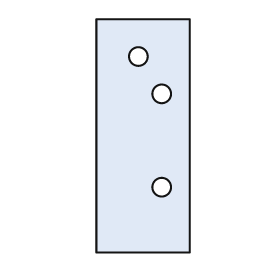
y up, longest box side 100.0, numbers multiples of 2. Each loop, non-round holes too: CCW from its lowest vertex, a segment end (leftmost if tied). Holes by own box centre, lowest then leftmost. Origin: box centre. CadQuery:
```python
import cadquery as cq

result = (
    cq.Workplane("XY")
    .moveTo(-20.0, -50.0)
    .lineTo(20.0, -50.0)
    .lineTo(20.0, 50.0)
    .lineTo(-20.0, 50.0)
    .close()
    .moveTo(8.0, -22.0)
    .circle(4.0)
    .moveTo(8.0, 18.0)
    .circle(4.0)
    .moveTo(-2.0, 34.0)
    .circle(4.0)
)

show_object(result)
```